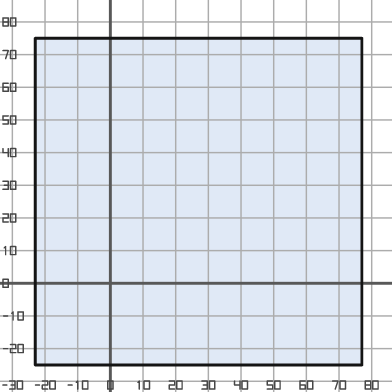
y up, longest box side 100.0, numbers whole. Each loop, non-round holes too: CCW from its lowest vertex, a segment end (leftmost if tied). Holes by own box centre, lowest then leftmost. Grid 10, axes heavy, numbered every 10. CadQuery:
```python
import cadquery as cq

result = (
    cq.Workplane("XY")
    .moveTo(-23.0, -25.0)
    .lineTo(77.0, -25.0)
    .lineTo(77.0, 75.0)
    .lineTo(-23.0, 75.0)
    .close()
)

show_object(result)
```